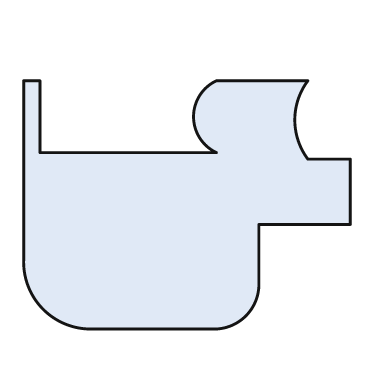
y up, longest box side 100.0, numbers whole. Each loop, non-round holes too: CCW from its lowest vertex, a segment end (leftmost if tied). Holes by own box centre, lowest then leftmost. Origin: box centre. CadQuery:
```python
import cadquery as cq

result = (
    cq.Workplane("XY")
    .moveTo(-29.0, -38.0)
    .lineTo(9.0, -38.0)
    .threePointArc((18.0, -34.0), (22.0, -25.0))
    .lineTo(22.0, -6.0)
    .lineTo(50.0, -6.0)
    .lineTo(50.0, 14.0)
    .lineTo(37.0, 14.0)
    .threePointArc((33.0, 26.0), (37.0, 38.0))
    .lineTo(9.0, 38.0)
    .threePointArc((2.0, 27.0), (9.0, 16.0))
    .lineTo(-45.0, 16.0)
    .lineTo(-45.0, 38.0)
    .lineTo(-50.0, 38.0)
    .lineTo(-50.0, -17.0)
    .threePointArc((-44.0, -32.0), (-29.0, -38.0))
    .close()
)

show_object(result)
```